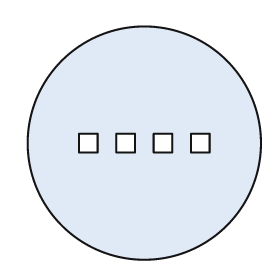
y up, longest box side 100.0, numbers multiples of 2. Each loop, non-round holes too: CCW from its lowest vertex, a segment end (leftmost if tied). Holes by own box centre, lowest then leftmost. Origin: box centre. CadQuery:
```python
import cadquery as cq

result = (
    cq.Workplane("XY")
    .moveTo(0.0, 0.0)
    .circle(50.0)
    .moveTo(-28.0, -4.0)
    .lineTo(-20.0, -4.0)
    .lineTo(-20.0, 4.0)
    .lineTo(-28.0, 4.0)
    .close()
    .moveTo(-12.0, -4.0)
    .lineTo(-4.0, -4.0)
    .lineTo(-4.0, 4.0)
    .lineTo(-12.0, 4.0)
    .close()
    .moveTo(4.0, -4.0)
    .lineTo(12.0, -4.0)
    .lineTo(12.0, 4.0)
    .lineTo(4.0, 4.0)
    .close()
    .moveTo(20.0, -4.0)
    .lineTo(28.0, -4.0)
    .lineTo(28.0, 4.0)
    .lineTo(20.0, 4.0)
    .close()
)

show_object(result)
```